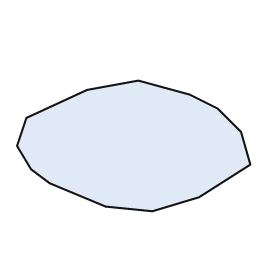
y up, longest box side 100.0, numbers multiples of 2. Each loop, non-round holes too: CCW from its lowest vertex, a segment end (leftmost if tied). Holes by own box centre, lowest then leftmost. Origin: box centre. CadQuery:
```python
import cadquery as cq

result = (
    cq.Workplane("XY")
    .moveTo(8.0, -28.0)
    .lineTo(28.0, -22.0)
    .lineTo(50.0, -8.0)
    .lineTo(46.0, 6.0)
    .lineTo(36.0, 16.0)
    .lineTo(24.0, 22.0)
    .lineTo(2.0, 28.0)
    .lineTo(-20.0, 24.0)
    .lineTo(-46.0, 12.0)
    .lineTo(-50.0, 0.0)
    .lineTo(-44.0, -10.0)
    .lineTo(-36.0, -16.0)
    .lineTo(-12.0, -26.0)
    .close()
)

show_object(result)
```